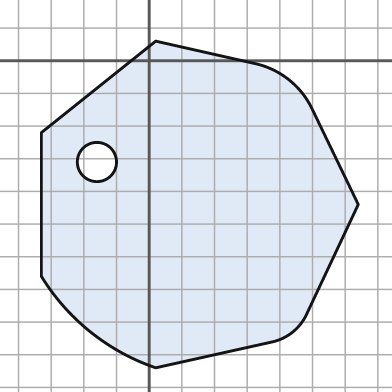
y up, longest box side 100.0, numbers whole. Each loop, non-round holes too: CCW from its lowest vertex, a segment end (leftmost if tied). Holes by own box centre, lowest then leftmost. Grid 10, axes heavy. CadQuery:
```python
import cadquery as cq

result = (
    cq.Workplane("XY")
    .moveTo(2.0, -94.0)
    .lineTo(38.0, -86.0)
    .threePointArc((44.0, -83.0), (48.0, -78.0))
    .lineTo(64.0, -44.0)
    .lineTo(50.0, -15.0)
    .threePointArc((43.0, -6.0), (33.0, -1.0))
    .lineTo(2.0, 6.0)
    .lineTo(-33.0, -22.0)
    .lineTo(-33.0, -66.0)
    .threePointArc((-18.0, -83.0), (2.0, -94.0))
    .close()
    .moveTo(-16.0, -31.0)
    .circle(6.0)
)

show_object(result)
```